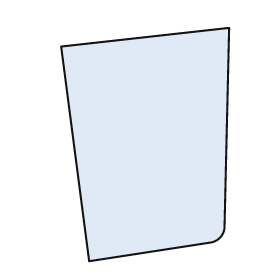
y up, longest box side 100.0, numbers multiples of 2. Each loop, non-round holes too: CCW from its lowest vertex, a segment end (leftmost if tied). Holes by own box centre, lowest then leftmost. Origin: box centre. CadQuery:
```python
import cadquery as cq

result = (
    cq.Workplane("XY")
    .moveTo(-24.0, -50.0)
    .lineTo(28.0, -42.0)
    .threePointArc((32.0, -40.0), (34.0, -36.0))
    .lineTo(36.0, 50.0)
    .lineTo(-36.0, 42.0)
    .close()
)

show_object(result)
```